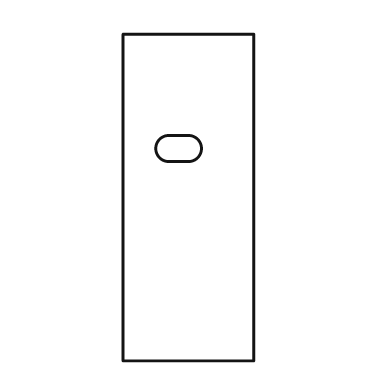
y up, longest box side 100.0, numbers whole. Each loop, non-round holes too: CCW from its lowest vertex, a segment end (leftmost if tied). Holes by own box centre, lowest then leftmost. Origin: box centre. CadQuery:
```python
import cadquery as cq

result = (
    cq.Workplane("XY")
    .moveTo(-20.0, -50.0)
    .lineTo(20.0, -50.0)
    .lineTo(20.0, 50.0)
    .lineTo(-20.0, 50.0)
    .close()
    .moveTo(-6.0, 11.0)
    .lineTo(0.0, 11.0)
    .threePointArc((4.0, 15.0), (0.0, 19.0))
    .lineTo(-6.0, 19.0)
    .threePointArc((-10.0, 15.0), (-6.0, 11.0))
    .close()
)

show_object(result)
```